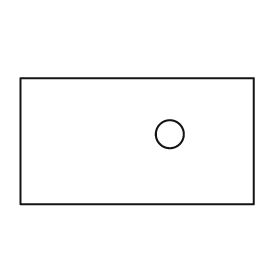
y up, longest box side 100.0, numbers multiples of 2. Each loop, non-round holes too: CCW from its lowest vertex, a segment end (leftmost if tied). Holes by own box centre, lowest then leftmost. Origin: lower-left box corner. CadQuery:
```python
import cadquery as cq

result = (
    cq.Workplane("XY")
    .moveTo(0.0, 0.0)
    .lineTo(100.0, 0.0)
    .lineTo(100.0, 54.0)
    .lineTo(0.0, 54.0)
    .close()
    .moveTo(64.0, 30.0)
    .circle(6.0)
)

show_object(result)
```